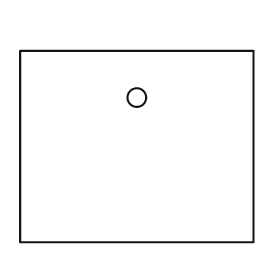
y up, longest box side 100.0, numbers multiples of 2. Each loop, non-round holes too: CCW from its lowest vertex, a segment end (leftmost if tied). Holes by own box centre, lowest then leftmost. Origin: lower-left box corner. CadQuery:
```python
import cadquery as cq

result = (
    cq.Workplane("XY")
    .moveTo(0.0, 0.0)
    .lineTo(100.0, 0.0)
    .lineTo(100.0, 82.0)
    .lineTo(0.0, 82.0)
    .close()
    .moveTo(50.0, 62.0)
    .circle(4.0)
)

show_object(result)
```